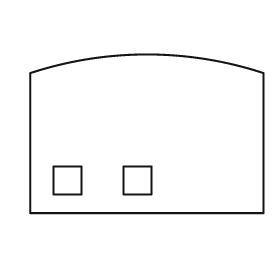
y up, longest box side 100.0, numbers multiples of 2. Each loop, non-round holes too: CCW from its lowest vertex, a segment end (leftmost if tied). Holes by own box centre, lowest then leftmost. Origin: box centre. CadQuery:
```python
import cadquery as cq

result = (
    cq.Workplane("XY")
    .moveTo(-50.0, -34.0)
    .lineTo(50.0, -34.0)
    .lineTo(50.0, 26.0)
    .threePointArc((0.0, 34.0), (-50.0, 26.0))
    .close()
    .moveTo(-40.0, -26.0)
    .lineTo(-28.0, -26.0)
    .lineTo(-28.0, -14.0)
    .lineTo(-40.0, -14.0)
    .close()
    .moveTo(-10.0, -26.0)
    .lineTo(2.0, -26.0)
    .lineTo(2.0, -14.0)
    .lineTo(-10.0, -14.0)
    .close()
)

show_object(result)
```